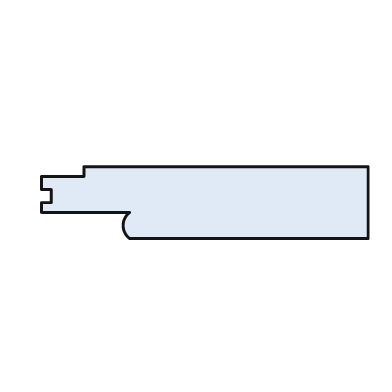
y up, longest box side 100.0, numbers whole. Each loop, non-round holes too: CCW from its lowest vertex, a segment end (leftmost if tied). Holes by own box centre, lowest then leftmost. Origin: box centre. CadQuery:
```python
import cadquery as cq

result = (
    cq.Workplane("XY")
    .moveTo(-23.0, -11.0)
    .lineTo(50.0, -11.0)
    .lineTo(50.0, 11.0)
    .lineTo(-37.0, 11.0)
    .lineTo(-37.0, 8.0)
    .lineTo(-50.0, 8.0)
    .lineTo(-50.0, 4.0)
    .lineTo(-47.0, 4.0)
    .lineTo(-47.0, 0.0)
    .lineTo(-50.0, 0.0)
    .lineTo(-50.0, -3.0)
    .lineTo(-23.0, -3.0)
    .threePointArc((-25.0, -7.0), (-23.0, -11.0))
    .close()
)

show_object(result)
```